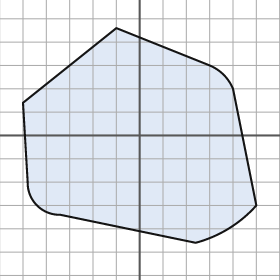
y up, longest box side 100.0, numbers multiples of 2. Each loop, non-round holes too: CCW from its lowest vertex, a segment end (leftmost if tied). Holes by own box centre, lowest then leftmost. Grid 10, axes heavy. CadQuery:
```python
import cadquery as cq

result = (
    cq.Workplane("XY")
    .moveTo(24.0, -46.0)
    .threePointArc((38.0, -40.0), (50.0, -30.0))
    .lineTo(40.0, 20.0)
    .threePointArc((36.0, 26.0), (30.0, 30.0))
    .lineTo(-10.0, 46.0)
    .lineTo(-50.0, 14.0)
    .lineTo(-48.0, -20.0)
    .threePointArc((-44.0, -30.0), (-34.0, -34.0))
    .close()
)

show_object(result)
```